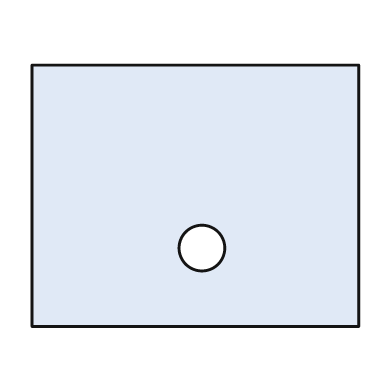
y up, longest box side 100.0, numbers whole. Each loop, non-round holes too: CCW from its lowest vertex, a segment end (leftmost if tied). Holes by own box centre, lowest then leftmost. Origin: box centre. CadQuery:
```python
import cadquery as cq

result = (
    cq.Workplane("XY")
    .moveTo(-50.0, -40.0)
    .lineTo(50.0, -40.0)
    .lineTo(50.0, 40.0)
    .lineTo(-50.0, 40.0)
    .close()
    .moveTo(2.0, -16.0)
    .circle(7.0)
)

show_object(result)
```